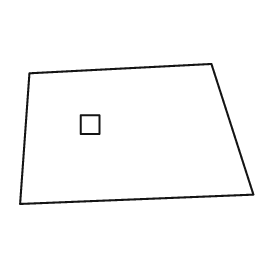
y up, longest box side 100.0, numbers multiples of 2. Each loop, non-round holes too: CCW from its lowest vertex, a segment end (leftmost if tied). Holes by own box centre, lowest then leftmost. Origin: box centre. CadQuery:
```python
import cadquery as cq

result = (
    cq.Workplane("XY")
    .moveTo(-50.0, -30.0)
    .lineTo(50.0, -26.0)
    .lineTo(32.0, 30.0)
    .lineTo(-46.0, 26.0)
    .close()
    .moveTo(-24.0, 0.0)
    .lineTo(-16.0, 0.0)
    .lineTo(-16.0, 8.0)
    .lineTo(-24.0, 8.0)
    .close()
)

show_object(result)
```